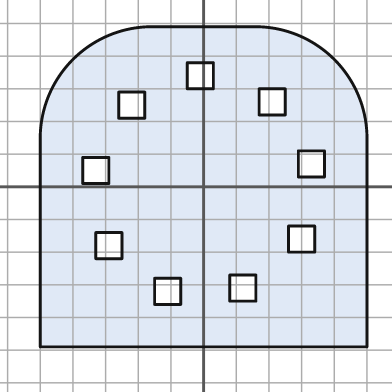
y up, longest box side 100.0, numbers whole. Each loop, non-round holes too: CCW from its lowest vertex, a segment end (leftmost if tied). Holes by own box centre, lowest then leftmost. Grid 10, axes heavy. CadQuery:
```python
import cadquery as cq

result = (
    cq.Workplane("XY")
    .moveTo(-50.0, -49.0)
    .lineTo(50.0, -49.0)
    .lineTo(50.0, 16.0)
    .threePointArc((40.0, 39.0), (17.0, 49.0))
    .lineTo(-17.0, 49.0)
    .threePointArc((-40.0, 39.0), (-50.0, 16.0))
    .close()
    .moveTo(-15.0, -36.0)
    .lineTo(-7.0, -36.0)
    .lineTo(-7.0, -28.0)
    .lineTo(-15.0, -28.0)
    .close()
    .moveTo(8.0, -35.0)
    .lineTo(16.0, -35.0)
    .lineTo(16.0, -27.0)
    .lineTo(8.0, -27.0)
    .close()
    .moveTo(-33.0, -22.0)
    .lineTo(-25.0, -22.0)
    .lineTo(-25.0, -14.0)
    .lineTo(-33.0, -14.0)
    .close()
    .moveTo(26.0, -20.0)
    .lineTo(34.0, -20.0)
    .lineTo(34.0, -12.0)
    .lineTo(26.0, -12.0)
    .close()
    .moveTo(-37.0, 1.0)
    .lineTo(-29.0, 1.0)
    .lineTo(-29.0, 9.0)
    .lineTo(-37.0, 9.0)
    .close()
    .moveTo(29.0, 3.0)
    .lineTo(37.0, 3.0)
    .lineTo(37.0, 11.0)
    .lineTo(29.0, 11.0)
    .close()
    .moveTo(-26.0, 21.0)
    .lineTo(-18.0, 21.0)
    .lineTo(-18.0, 29.0)
    .lineTo(-26.0, 29.0)
    .close()
    .moveTo(17.0, 22.0)
    .lineTo(25.0, 22.0)
    .lineTo(25.0, 30.0)
    .lineTo(17.0, 30.0)
    .close()
    .moveTo(-5.0, 30.0)
    .lineTo(3.0, 30.0)
    .lineTo(3.0, 38.0)
    .lineTo(-5.0, 38.0)
    .close()
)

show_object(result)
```